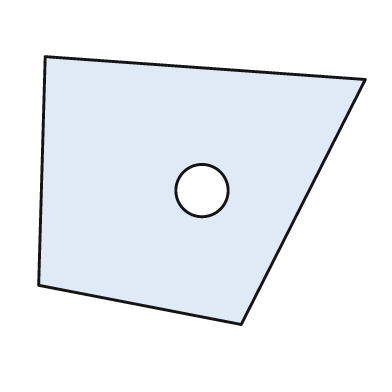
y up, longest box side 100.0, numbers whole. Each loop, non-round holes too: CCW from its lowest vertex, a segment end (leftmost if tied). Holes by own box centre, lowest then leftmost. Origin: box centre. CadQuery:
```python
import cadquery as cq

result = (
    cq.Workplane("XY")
    .moveTo(12.0, -41.0)
    .lineTo(50.0, 34.0)
    .lineTo(-48.0, 41.0)
    .lineTo(-50.0, -29.0)
    .close()
    .moveTo(0.0, 0.0)
    .circle(8.0)
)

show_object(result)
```